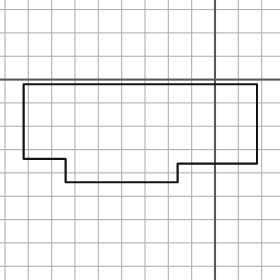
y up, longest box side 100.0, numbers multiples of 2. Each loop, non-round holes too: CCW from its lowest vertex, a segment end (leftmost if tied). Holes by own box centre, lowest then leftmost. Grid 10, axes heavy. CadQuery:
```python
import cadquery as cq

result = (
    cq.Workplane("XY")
    .moveTo(-64.0, -44.0)
    .lineTo(-16.0, -44.0)
    .lineTo(-16.0, -36.0)
    .lineTo(18.0, -36.0)
    .lineTo(18.0, -2.0)
    .lineTo(-82.0, -2.0)
    .lineTo(-82.0, -34.0)
    .lineTo(-64.0, -34.0)
    .close()
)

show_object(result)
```